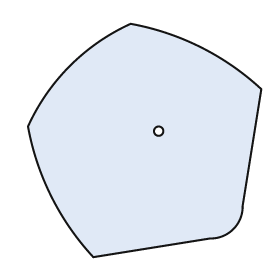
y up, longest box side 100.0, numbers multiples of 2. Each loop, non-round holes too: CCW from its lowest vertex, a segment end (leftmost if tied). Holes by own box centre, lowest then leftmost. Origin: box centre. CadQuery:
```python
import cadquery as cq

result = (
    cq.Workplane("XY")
    .moveTo(-22.0, -50.0)
    .lineTo(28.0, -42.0)
    .threePointArc((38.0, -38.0), (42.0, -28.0))
    .lineTo(50.0, 22.0)
    .threePointArc((24.0, 40.0), (-6.0, 50.0))
    .threePointArc((-32.0, 32.0), (-50.0, 6.0))
    .threePointArc((-40.0, -24.0), (-22.0, -50.0))
    .close()
    .moveTo(6.0, 4.0)
    .circle(2.0)
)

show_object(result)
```